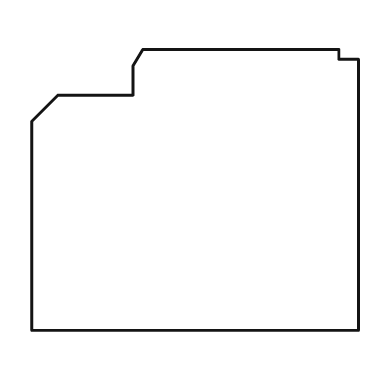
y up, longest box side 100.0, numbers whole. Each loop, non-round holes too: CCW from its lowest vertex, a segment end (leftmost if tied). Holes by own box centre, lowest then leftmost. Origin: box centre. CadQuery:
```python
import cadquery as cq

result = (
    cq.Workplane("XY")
    .moveTo(-50.0, -43.0)
    .lineTo(50.0, -43.0)
    .lineTo(50.0, 40.0)
    .lineTo(44.0, 40.0)
    .lineTo(44.0, 43.0)
    .lineTo(-16.0, 43.0)
    .lineTo(-19.0, 38.0)
    .lineTo(-19.0, 29.0)
    .lineTo(-42.0, 29.0)
    .lineTo(-50.0, 21.0)
    .close()
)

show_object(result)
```